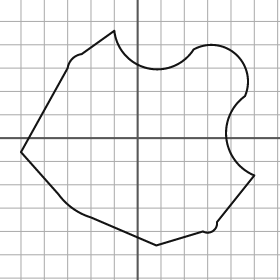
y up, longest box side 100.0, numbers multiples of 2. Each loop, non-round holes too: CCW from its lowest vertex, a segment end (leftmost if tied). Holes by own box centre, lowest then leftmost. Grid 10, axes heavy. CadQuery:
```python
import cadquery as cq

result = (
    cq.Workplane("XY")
    .moveTo(8.0, -46.0)
    .lineTo(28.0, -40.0)
    .threePointArc((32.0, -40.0), (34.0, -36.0))
    .lineTo(50.0, -16.0)
    .threePointArc((38.0, 0.0), (46.0, 18.0))
    .threePointArc((42.0, 36.0), (24.0, 38.0))
    .threePointArc((4.0, 30.0), (-10.0, 46.0))
    .lineTo(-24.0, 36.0)
    .threePointArc((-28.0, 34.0), (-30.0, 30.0))
    .lineTo(-50.0, -6.0)
    .lineTo(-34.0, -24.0)
    .threePointArc((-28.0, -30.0), (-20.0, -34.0))
    .close()
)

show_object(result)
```